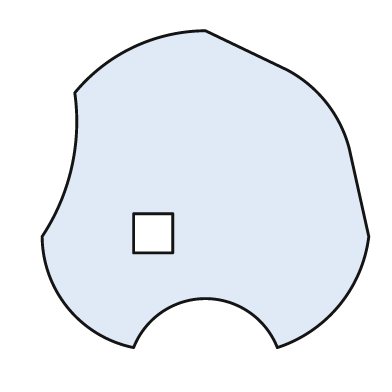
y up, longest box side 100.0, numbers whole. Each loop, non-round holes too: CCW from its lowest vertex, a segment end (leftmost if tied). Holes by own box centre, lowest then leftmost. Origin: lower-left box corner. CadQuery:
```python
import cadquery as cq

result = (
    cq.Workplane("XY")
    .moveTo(28.0, 0.0)
    .threePointArc((50.0, 15.0), (72.0, 0.0))
    .threePointArc((91.0, 13.0), (100.0, 34.0))
    .lineTo(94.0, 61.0)
    .threePointArc((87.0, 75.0), (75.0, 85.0))
    .lineTo(50.0, 97.0)
    .threePointArc((28.0, 92.0), (10.0, 78.0))
    .threePointArc((9.0, 55.0), (0.0, 34.0))
    .threePointArc((8.0, 12.0), (28.0, 0.0))
    .close()
    .moveTo(28.0, 29.0)
    .lineTo(40.0, 29.0)
    .lineTo(40.0, 41.0)
    .lineTo(28.0, 41.0)
    .close()
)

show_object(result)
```